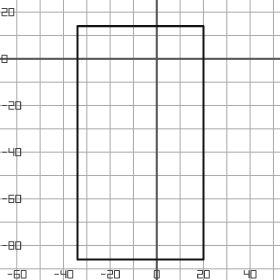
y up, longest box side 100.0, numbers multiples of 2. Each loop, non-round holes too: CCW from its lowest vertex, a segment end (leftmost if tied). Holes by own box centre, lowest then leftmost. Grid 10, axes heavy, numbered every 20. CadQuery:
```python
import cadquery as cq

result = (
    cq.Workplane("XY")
    .moveTo(-34.0, -86.0)
    .lineTo(20.0, -86.0)
    .lineTo(20.0, 14.0)
    .lineTo(-34.0, 14.0)
    .close()
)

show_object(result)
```